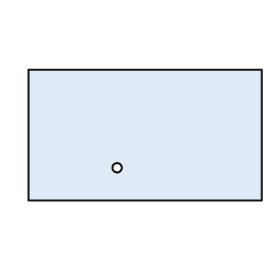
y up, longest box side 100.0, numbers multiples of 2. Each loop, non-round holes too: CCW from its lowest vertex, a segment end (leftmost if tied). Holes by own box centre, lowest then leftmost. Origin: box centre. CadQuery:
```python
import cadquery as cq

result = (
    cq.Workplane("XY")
    .moveTo(-50.0, -28.0)
    .lineTo(50.0, -28.0)
    .lineTo(50.0, 28.0)
    .lineTo(-50.0, 28.0)
    .close()
    .moveTo(-12.0, -14.0)
    .circle(2.0)
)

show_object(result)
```